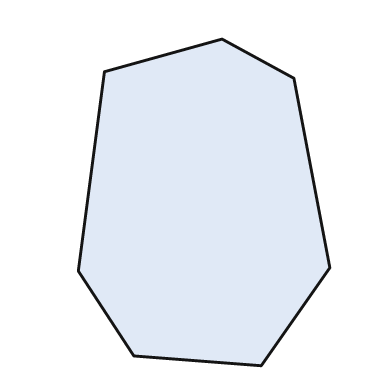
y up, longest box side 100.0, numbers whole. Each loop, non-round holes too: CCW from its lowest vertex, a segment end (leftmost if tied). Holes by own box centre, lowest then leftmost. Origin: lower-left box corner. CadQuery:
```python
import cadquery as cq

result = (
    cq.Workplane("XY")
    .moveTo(56.0, 0.0)
    .lineTo(77.0, 30.0)
    .lineTo(66.0, 88.0)
    .lineTo(44.0, 100.0)
    .lineTo(8.0, 90.0)
    .lineTo(0.0, 29.0)
    .lineTo(17.0, 3.0)
    .close()
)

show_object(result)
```